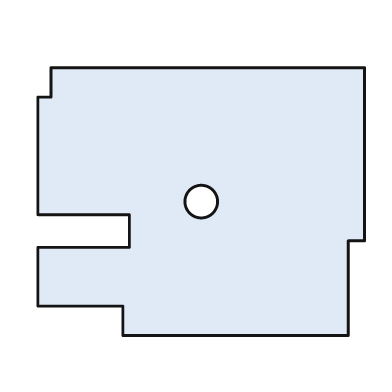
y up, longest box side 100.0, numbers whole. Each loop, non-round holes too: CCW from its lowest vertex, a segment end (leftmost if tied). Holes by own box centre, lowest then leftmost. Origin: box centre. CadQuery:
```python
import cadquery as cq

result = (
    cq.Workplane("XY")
    .moveTo(-24.0, -41.0)
    .lineTo(45.0, -41.0)
    .lineTo(45.0, -12.0)
    .lineTo(50.0, -12.0)
    .lineTo(50.0, 41.0)
    .lineTo(-46.0, 41.0)
    .lineTo(-46.0, 32.0)
    .lineTo(-50.0, 32.0)
    .lineTo(-50.0, -4.0)
    .lineTo(-22.0, -4.0)
    .lineTo(-22.0, -14.0)
    .lineTo(-50.0, -14.0)
    .lineTo(-50.0, -32.0)
    .lineTo(-24.0, -32.0)
    .close()
    .moveTo(0.0, 0.0)
    .circle(5.0)
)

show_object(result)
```